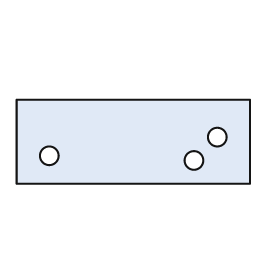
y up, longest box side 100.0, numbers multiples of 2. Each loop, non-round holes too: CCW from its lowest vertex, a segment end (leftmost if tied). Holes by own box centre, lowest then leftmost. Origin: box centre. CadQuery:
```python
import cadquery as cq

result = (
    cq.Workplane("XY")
    .moveTo(-50.0, -18.0)
    .lineTo(50.0, -18.0)
    .lineTo(50.0, 18.0)
    .lineTo(-50.0, 18.0)
    .close()
    .moveTo(26.0, -8.0)
    .circle(4.0)
    .moveTo(-36.0, -6.0)
    .circle(4.0)
    .moveTo(36.0, 2.0)
    .circle(4.0)
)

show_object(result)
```